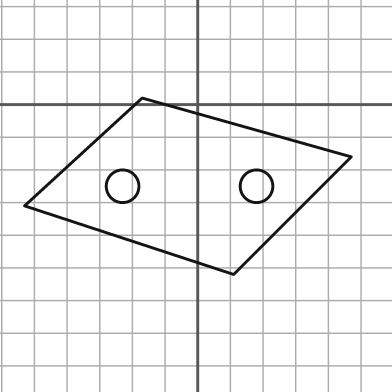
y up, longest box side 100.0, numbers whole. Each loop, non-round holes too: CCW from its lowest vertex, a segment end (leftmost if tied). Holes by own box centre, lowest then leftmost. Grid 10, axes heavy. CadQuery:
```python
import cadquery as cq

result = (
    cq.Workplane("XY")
    .moveTo(11.0, -52.0)
    .lineTo(47.0, -16.0)
    .lineTo(-17.0, 2.0)
    .lineTo(-53.0, -31.0)
    .close()
    .moveTo(-23.0, -25.0)
    .circle(5.0)
    .moveTo(18.0, -25.0)
    .circle(5.0)
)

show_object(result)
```